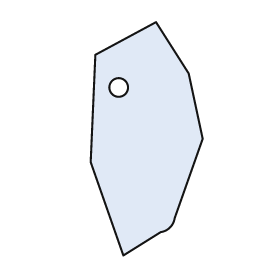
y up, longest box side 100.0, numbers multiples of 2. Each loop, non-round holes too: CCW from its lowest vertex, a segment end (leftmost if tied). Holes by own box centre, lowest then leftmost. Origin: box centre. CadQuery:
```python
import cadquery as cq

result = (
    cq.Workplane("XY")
    .moveTo(-10.0, -50.0)
    .lineTo(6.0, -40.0)
    .threePointArc((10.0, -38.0), (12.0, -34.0))
    .lineTo(24.0, 0.0)
    .lineTo(18.0, 28.0)
    .lineTo(4.0, 50.0)
    .lineTo(-22.0, 36.0)
    .lineTo(-24.0, -10.0)
    .close()
    .moveTo(-12.0, 22.0)
    .circle(4.0)
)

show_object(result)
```